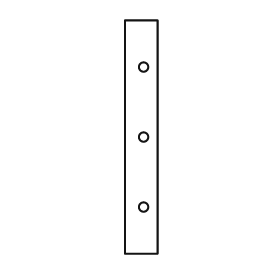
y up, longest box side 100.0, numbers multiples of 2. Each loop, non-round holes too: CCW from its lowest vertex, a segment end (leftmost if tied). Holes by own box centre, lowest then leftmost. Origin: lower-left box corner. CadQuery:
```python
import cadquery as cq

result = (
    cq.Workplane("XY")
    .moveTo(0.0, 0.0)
    .lineTo(14.0, 0.0)
    .lineTo(14.0, 100.0)
    .lineTo(0.0, 100.0)
    .close()
    .moveTo(8.0, 20.0)
    .circle(2.0)
    .moveTo(8.0, 50.0)
    .circle(2.0)
    .moveTo(8.0, 80.0)
    .circle(2.0)
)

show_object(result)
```